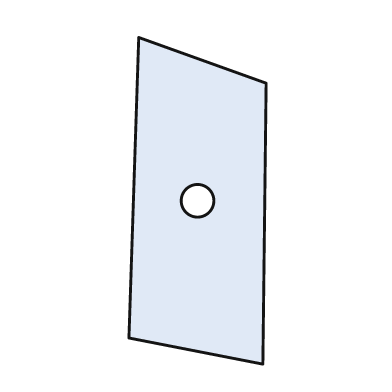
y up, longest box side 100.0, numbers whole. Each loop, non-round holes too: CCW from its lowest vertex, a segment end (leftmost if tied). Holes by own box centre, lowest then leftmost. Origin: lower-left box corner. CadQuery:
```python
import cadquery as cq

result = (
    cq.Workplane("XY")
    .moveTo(41.0, 0.0)
    .lineTo(42.0, 86.0)
    .lineTo(3.0, 100.0)
    .lineTo(0.0, 8.0)
    .close()
    .moveTo(21.0, 50.0)
    .circle(5.0)
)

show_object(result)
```